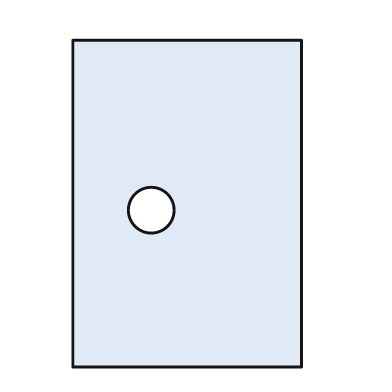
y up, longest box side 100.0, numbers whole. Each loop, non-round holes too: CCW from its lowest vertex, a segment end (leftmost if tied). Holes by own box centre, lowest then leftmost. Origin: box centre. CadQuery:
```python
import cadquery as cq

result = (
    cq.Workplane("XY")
    .moveTo(-35.0, -50.0)
    .lineTo(35.0, -50.0)
    .lineTo(35.0, 50.0)
    .lineTo(-35.0, 50.0)
    .close()
    .moveTo(-11.0, -2.0)
    .circle(7.0)
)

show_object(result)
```